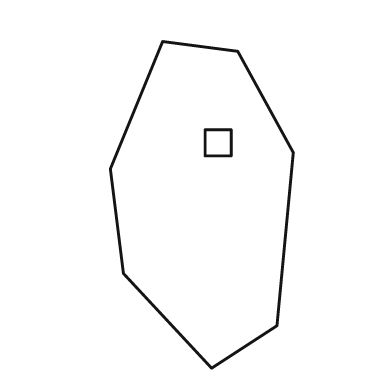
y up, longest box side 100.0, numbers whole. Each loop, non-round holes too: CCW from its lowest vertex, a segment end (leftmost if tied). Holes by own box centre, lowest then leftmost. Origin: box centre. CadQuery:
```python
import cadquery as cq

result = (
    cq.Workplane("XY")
    .moveTo(3.0, -50.0)
    .lineTo(23.0, -37.0)
    .lineTo(28.0, 16.0)
    .lineTo(11.0, 47.0)
    .lineTo(-12.0, 50.0)
    .lineTo(-28.0, 11.0)
    .lineTo(-24.0, -21.0)
    .close()
    .moveTo(1.0, 15.0)
    .lineTo(9.0, 15.0)
    .lineTo(9.0, 23.0)
    .lineTo(1.0, 23.0)
    .close()
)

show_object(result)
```